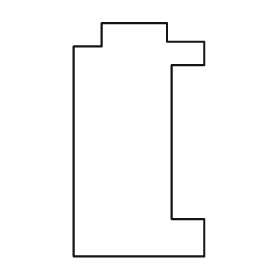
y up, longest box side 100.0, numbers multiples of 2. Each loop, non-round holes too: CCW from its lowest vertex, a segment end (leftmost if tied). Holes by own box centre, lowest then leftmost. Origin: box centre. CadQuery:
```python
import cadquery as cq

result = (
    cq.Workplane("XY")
    .moveTo(-28.0, -50.0)
    .lineTo(28.0, -50.0)
    .lineTo(28.0, -34.0)
    .lineTo(14.0, -34.0)
    .lineTo(14.0, 32.0)
    .lineTo(28.0, 32.0)
    .lineTo(28.0, 42.0)
    .lineTo(12.0, 42.0)
    .lineTo(12.0, 50.0)
    .lineTo(-16.0, 50.0)
    .lineTo(-16.0, 40.0)
    .lineTo(-28.0, 40.0)
    .close()
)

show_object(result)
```